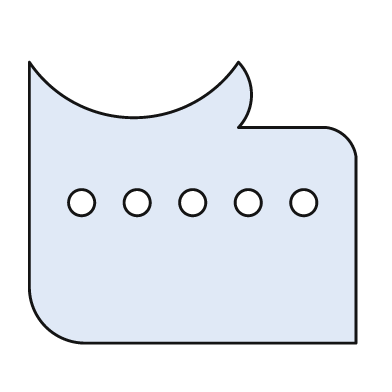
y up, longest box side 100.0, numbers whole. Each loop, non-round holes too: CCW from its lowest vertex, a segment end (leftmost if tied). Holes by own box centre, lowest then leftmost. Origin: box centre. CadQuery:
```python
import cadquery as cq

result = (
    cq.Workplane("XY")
    .moveTo(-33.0, -43.0)
    .lineTo(50.0, -43.0)
    .lineTo(50.0, 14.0)
    .threePointArc((47.0, 20.0), (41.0, 23.0))
    .lineTo(14.0, 23.0)
    .threePointArc((18.0, 33.0), (14.0, 43.0))
    .threePointArc((-18.0, 26.0), (-50.0, 43.0))
    .lineTo(-50.0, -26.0)
    .threePointArc((-45.0, -38.0), (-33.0, -43.0))
    .close()
    .moveTo(-34.0, 0.0)
    .circle(4.0)
    .moveTo(-17.0, 0.0)
    .circle(4.0)
    .moveTo(0.0, 0.0)
    .circle(4.0)
    .moveTo(17.0, 0.0)
    .circle(4.0)
    .moveTo(34.0, 0.0)
    .circle(4.0)
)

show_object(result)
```